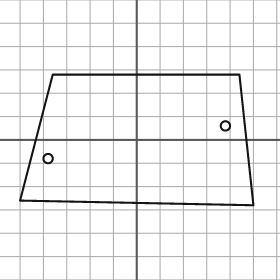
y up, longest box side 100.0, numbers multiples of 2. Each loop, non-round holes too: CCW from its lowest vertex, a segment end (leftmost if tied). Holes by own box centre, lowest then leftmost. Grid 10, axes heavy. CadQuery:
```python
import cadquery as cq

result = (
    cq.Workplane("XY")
    .moveTo(50.0, -28.0)
    .lineTo(44.0, 28.0)
    .lineTo(-36.0, 28.0)
    .lineTo(-50.0, -26.0)
    .close()
    .moveTo(-38.0, -8.0)
    .circle(2.0)
    .moveTo(38.0, 6.0)
    .circle(2.0)
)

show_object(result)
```